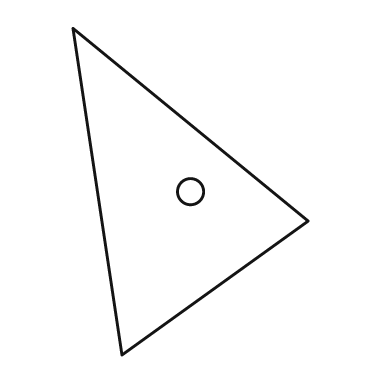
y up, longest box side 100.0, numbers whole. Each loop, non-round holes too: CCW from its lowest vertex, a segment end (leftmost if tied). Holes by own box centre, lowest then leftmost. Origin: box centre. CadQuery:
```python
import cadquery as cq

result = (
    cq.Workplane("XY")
    .moveTo(-21.0, -50.0)
    .lineTo(36.0, -9.0)
    .lineTo(-36.0, 50.0)
    .close()
    .moveTo(0.0, 0.0)
    .circle(4.0)
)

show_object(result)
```